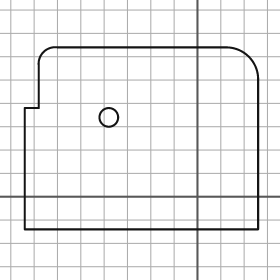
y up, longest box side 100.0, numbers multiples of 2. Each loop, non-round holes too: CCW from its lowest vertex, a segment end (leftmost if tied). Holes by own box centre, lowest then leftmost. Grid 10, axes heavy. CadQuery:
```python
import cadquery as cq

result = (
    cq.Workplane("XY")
    .moveTo(-74.0, -14.0)
    .lineTo(26.0, -14.0)
    .lineTo(26.0, 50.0)
    .threePointArc((22.0, 60.0), (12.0, 64.0))
    .lineTo(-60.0, 64.0)
    .threePointArc((-66.0, 62.0), (-68.0, 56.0))
    .lineTo(-68.0, 38.0)
    .lineTo(-74.0, 38.0)
    .close()
    .moveTo(-38.0, 34.0)
    .circle(4.0)
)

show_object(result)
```